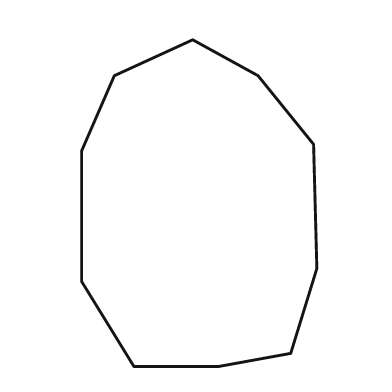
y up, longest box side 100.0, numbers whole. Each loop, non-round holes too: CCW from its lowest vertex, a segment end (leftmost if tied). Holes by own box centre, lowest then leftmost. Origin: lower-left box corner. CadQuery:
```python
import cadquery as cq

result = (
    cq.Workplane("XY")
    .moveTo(16.0, 0.0)
    .lineTo(42.0, 0.0)
    .lineTo(64.0, 4.0)
    .lineTo(72.0, 30.0)
    .lineTo(71.0, 68.0)
    .lineTo(54.0, 89.0)
    .lineTo(34.0, 100.0)
    .lineTo(10.0, 89.0)
    .lineTo(0.0, 66.0)
    .lineTo(0.0, 26.0)
    .close()
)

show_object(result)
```